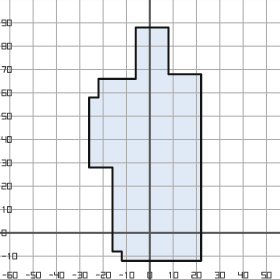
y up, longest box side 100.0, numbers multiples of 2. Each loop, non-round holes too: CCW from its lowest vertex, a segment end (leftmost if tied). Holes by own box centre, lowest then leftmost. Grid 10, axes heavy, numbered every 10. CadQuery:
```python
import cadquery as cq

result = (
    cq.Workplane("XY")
    .moveTo(-12.0, -12.0)
    .lineTo(22.0, -12.0)
    .lineTo(22.0, 68.0)
    .lineTo(8.0, 68.0)
    .lineTo(8.0, 88.0)
    .lineTo(-6.0, 88.0)
    .lineTo(-6.0, 66.0)
    .lineTo(-22.0, 66.0)
    .lineTo(-22.0, 58.0)
    .lineTo(-26.0, 58.0)
    .lineTo(-26.0, 28.0)
    .lineTo(-16.0, 28.0)
    .lineTo(-16.0, -8.0)
    .lineTo(-12.0, -8.0)
    .close()
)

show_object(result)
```